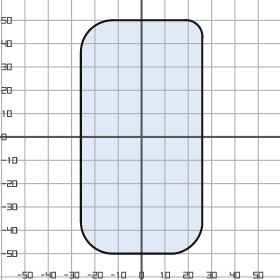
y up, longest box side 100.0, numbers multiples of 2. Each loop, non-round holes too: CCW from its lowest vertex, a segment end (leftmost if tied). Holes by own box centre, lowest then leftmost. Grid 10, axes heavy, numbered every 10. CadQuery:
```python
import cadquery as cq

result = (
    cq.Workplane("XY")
    .moveTo(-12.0, -50.0)
    .lineTo(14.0, -50.0)
    .threePointArc((22.0, -46.0), (26.0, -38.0))
    .lineTo(26.0, 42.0)
    .threePointArc((24.0, 48.0), (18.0, 50.0))
    .lineTo(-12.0, 50.0)
    .threePointArc((-22.0, 46.0), (-26.0, 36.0))
    .lineTo(-26.0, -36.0)
    .threePointArc((-22.0, -46.0), (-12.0, -50.0))
    .close()
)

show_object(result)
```